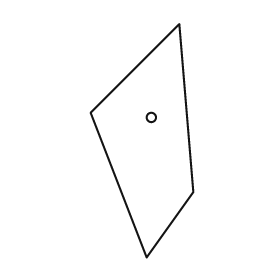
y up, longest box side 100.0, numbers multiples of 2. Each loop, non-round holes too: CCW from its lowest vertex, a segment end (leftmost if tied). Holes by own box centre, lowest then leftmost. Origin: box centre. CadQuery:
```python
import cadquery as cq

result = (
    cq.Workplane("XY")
    .moveTo(2.0, -50.0)
    .lineTo(22.0, -22.0)
    .lineTo(16.0, 50.0)
    .lineTo(-22.0, 12.0)
    .close()
    .moveTo(4.0, 10.0)
    .circle(2.0)
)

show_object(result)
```